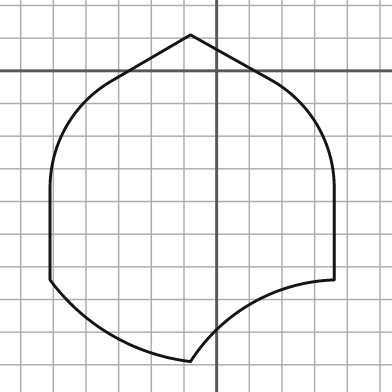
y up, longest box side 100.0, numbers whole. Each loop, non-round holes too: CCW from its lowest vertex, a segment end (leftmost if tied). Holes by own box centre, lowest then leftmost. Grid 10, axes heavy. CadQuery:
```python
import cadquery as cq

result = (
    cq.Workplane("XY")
    .moveTo(-8.0, -89.0)
    .threePointArc((11.0, -71.0), (36.0, -64.0))
    .lineTo(36.0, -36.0)
    .threePointArc((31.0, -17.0), (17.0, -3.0))
    .lineTo(-8.0, 11.0)
    .lineTo(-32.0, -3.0)
    .threePointArc((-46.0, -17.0), (-51.0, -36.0))
    .lineTo(-51.0, -64.0)
    .threePointArc((-32.0, -81.0), (-8.0, -89.0))
    .close()
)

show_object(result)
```